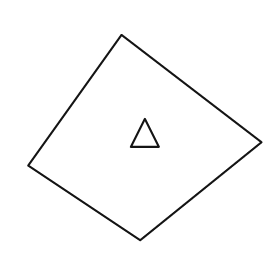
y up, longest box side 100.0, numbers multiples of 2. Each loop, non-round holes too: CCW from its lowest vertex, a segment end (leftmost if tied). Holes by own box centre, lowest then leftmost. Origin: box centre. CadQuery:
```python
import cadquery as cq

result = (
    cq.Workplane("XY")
    .moveTo(-2.0, -44.0)
    .lineTo(50.0, -2.0)
    .lineTo(-10.0, 44.0)
    .lineTo(-50.0, -12.0)
    .close()
    .moveTo(-6.0, -4.0)
    .lineTo(6.0, -4.0)
    .lineTo(0.0, 8.0)
    .close()
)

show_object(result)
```